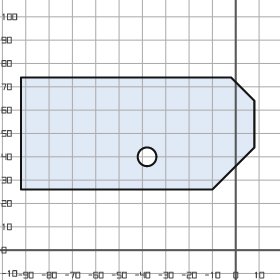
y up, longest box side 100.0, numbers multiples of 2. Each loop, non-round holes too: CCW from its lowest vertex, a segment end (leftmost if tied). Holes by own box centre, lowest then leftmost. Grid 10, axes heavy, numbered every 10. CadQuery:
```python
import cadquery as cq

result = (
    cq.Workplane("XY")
    .moveTo(-92.0, 26.0)
    .lineTo(-10.0, 26.0)
    .lineTo(8.0, 44.0)
    .lineTo(8.0, 64.0)
    .lineTo(-2.0, 74.0)
    .lineTo(-92.0, 74.0)
    .close()
    .moveTo(-38.0, 40.0)
    .circle(4.0)
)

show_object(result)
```